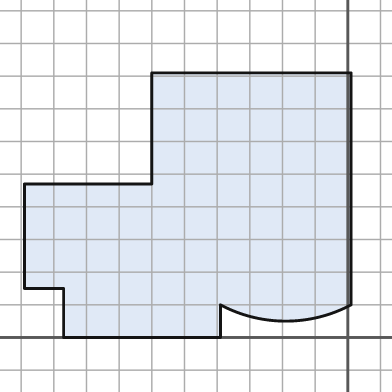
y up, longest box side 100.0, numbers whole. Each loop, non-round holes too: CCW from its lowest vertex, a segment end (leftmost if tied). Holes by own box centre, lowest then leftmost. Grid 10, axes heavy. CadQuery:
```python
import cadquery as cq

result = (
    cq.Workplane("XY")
    .moveTo(-87.0, 0.0)
    .lineTo(-39.0, 0.0)
    .lineTo(-39.0, 10.0)
    .threePointArc((-19.0, 5.0), (1.0, 10.0))
    .lineTo(1.0, 81.0)
    .lineTo(-60.0, 81.0)
    .lineTo(-60.0, 47.0)
    .lineTo(-99.0, 47.0)
    .lineTo(-99.0, 15.0)
    .lineTo(-87.0, 15.0)
    .close()
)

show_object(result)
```